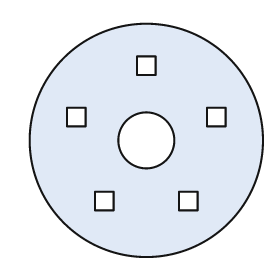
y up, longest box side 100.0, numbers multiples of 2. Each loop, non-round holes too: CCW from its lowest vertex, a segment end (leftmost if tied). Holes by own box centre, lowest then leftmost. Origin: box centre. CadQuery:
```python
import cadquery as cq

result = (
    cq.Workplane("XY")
    .moveTo(0.0, 0.0)
    .circle(50.0)
    .moveTo(-22.0, -30.0)
    .lineTo(-14.0, -30.0)
    .lineTo(-14.0, -22.0)
    .lineTo(-22.0, -22.0)
    .close()
    .moveTo(14.0, -30.0)
    .lineTo(22.0, -30.0)
    .lineTo(22.0, -22.0)
    .lineTo(14.0, -22.0)
    .close()
    .moveTo(0.0, 0.0)
    .circle(12.0)
    .moveTo(-34.0, 6.0)
    .lineTo(-26.0, 6.0)
    .lineTo(-26.0, 14.0)
    .lineTo(-34.0, 14.0)
    .close()
    .moveTo(26.0, 6.0)
    .lineTo(34.0, 6.0)
    .lineTo(34.0, 14.0)
    .lineTo(26.0, 14.0)
    .close()
    .moveTo(-4.0, 28.0)
    .lineTo(4.0, 28.0)
    .lineTo(4.0, 36.0)
    .lineTo(-4.0, 36.0)
    .close()
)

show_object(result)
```